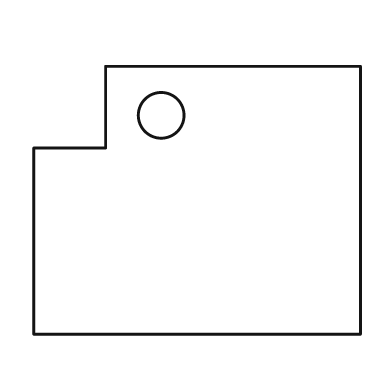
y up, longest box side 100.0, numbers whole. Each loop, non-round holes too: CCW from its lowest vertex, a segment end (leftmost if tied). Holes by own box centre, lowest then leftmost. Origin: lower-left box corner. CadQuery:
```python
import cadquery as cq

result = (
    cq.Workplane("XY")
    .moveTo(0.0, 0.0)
    .lineTo(100.0, 0.0)
    .lineTo(100.0, 82.0)
    .lineTo(22.0, 82.0)
    .lineTo(22.0, 57.0)
    .lineTo(0.0, 57.0)
    .close()
    .moveTo(39.0, 67.0)
    .circle(7.0)
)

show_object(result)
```